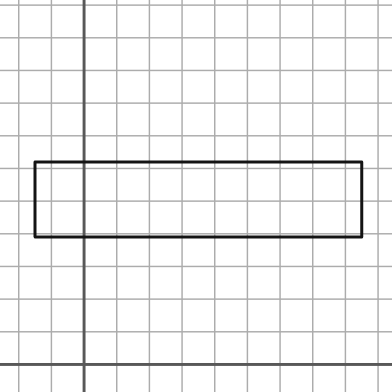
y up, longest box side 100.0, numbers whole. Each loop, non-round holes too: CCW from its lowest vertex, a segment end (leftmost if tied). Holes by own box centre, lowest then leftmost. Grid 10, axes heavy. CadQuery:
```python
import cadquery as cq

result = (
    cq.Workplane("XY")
    .moveTo(-15.0, 39.0)
    .lineTo(85.0, 39.0)
    .lineTo(85.0, 62.0)
    .lineTo(-15.0, 62.0)
    .close()
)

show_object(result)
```